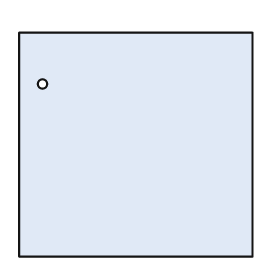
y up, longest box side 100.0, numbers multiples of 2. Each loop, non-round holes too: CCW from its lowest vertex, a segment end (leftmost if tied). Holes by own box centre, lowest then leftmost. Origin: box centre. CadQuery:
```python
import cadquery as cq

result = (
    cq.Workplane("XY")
    .moveTo(-50.0, -48.0)
    .lineTo(50.0, -48.0)
    .lineTo(50.0, 48.0)
    .lineTo(-50.0, 48.0)
    .close()
    .moveTo(-40.0, 26.0)
    .circle(2.0)
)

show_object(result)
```